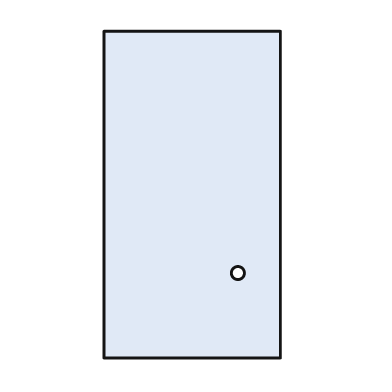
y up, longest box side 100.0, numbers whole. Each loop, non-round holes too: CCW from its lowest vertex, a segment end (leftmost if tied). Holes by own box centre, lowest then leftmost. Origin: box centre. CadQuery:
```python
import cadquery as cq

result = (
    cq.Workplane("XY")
    .moveTo(-27.0, -50.0)
    .lineTo(27.0, -50.0)
    .lineTo(27.0, 50.0)
    .lineTo(-27.0, 50.0)
    .close()
    .moveTo(14.0, -24.0)
    .circle(2.0)
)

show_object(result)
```